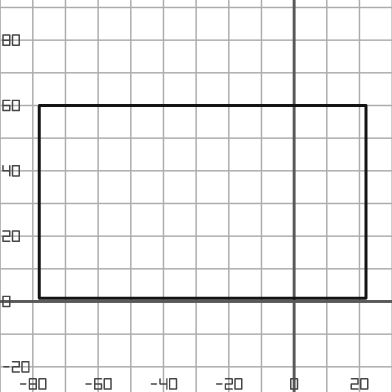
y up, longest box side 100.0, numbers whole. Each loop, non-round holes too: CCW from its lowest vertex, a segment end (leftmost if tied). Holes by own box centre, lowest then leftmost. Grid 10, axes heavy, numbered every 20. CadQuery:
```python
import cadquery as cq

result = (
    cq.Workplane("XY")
    .moveTo(-78.0, 1.0)
    .lineTo(22.0, 1.0)
    .lineTo(22.0, 60.0)
    .lineTo(-78.0, 60.0)
    .close()
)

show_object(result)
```